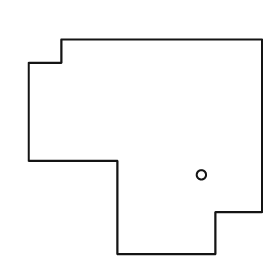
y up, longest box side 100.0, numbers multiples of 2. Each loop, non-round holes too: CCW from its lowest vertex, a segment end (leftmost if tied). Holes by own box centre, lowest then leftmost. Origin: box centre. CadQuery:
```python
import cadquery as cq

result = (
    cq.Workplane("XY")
    .moveTo(-12.0, -46.0)
    .lineTo(30.0, -46.0)
    .lineTo(30.0, -28.0)
    .lineTo(50.0, -28.0)
    .lineTo(50.0, 46.0)
    .lineTo(-36.0, 46.0)
    .lineTo(-36.0, 36.0)
    .lineTo(-50.0, 36.0)
    .lineTo(-50.0, -6.0)
    .lineTo(-12.0, -6.0)
    .close()
    .moveTo(24.0, -12.0)
    .circle(2.0)
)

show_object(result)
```